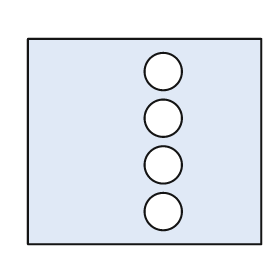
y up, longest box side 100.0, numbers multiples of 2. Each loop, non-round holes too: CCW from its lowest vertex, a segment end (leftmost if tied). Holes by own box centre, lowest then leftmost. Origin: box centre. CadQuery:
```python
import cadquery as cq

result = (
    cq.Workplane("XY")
    .moveTo(-50.0, -44.0)
    .lineTo(50.0, -44.0)
    .lineTo(50.0, 44.0)
    .lineTo(-50.0, 44.0)
    .close()
    .moveTo(8.0, -30.0)
    .circle(8.0)
    .moveTo(8.0, -10.0)
    .circle(8.0)
    .moveTo(8.0, 10.0)
    .circle(8.0)
    .moveTo(8.0, 30.0)
    .circle(8.0)
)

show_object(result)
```